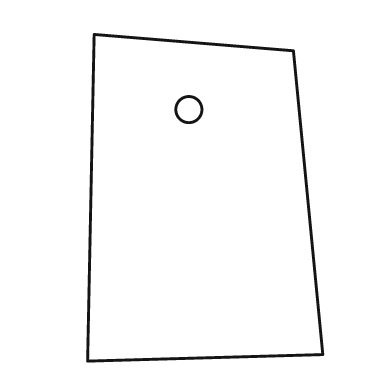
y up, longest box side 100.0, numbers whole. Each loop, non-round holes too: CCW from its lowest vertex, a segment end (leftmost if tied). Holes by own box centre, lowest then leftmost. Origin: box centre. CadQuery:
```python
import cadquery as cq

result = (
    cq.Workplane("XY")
    .moveTo(-36.0, -50.0)
    .lineTo(36.0, -48.0)
    .lineTo(27.0, 45.0)
    .lineTo(-34.0, 50.0)
    .close()
    .moveTo(-5.0, 27.0)
    .circle(4.0)
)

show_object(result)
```